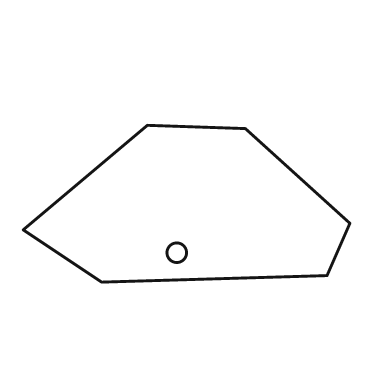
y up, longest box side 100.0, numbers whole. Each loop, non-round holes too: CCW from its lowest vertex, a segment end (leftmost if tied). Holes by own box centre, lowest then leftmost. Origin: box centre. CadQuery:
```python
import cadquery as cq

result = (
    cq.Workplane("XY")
    .moveTo(-26.0, -24.0)
    .lineTo(43.0, -22.0)
    .lineTo(50.0, -6.0)
    .lineTo(18.0, 23.0)
    .lineTo(-12.0, 24.0)
    .lineTo(-50.0, -8.0)
    .close()
    .moveTo(-3.0, -15.0)
    .circle(3.0)
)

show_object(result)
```